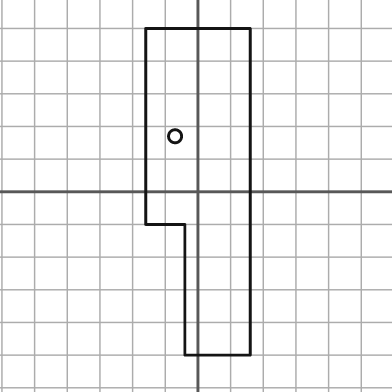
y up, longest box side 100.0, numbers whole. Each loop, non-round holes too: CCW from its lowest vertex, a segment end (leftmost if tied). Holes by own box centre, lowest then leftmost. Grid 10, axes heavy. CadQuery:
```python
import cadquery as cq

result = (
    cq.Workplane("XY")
    .moveTo(-4.0, -50.0)
    .lineTo(16.0, -50.0)
    .lineTo(16.0, 50.0)
    .lineTo(-16.0, 50.0)
    .lineTo(-16.0, -10.0)
    .lineTo(-4.0, -10.0)
    .close()
    .moveTo(-7.0, 17.0)
    .circle(2.0)
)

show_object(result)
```